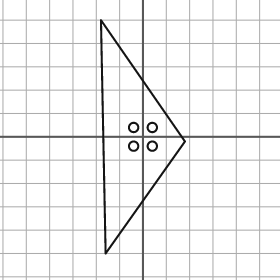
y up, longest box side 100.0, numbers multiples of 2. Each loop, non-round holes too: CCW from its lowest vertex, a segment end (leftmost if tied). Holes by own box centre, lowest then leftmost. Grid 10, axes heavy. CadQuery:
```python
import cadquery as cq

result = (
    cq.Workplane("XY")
    .moveTo(-16.0, -50.0)
    .lineTo(18.0, -2.0)
    .lineTo(-18.0, 50.0)
    .close()
    .moveTo(-4.0, -4.0)
    .circle(2.0)
    .moveTo(4.0, -4.0)
    .circle(2.0)
    .moveTo(-4.0, 4.0)
    .circle(2.0)
    .moveTo(4.0, 4.0)
    .circle(2.0)
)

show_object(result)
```